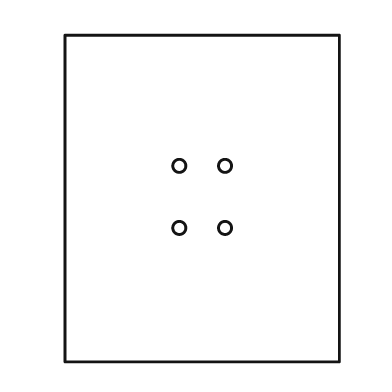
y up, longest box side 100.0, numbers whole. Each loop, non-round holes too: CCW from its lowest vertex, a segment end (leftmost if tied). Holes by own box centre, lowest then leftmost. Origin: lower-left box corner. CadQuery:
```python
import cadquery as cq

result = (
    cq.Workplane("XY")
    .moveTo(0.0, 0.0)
    .lineTo(84.0, 0.0)
    .lineTo(84.0, 100.0)
    .lineTo(0.0, 100.0)
    .close()
    .moveTo(35.0, 41.0)
    .circle(2.0)
    .moveTo(49.0, 41.0)
    .circle(2.0)
    .moveTo(35.0, 60.0)
    .circle(2.0)
    .moveTo(49.0, 60.0)
    .circle(2.0)
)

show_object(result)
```